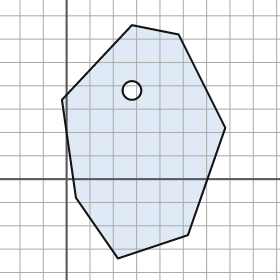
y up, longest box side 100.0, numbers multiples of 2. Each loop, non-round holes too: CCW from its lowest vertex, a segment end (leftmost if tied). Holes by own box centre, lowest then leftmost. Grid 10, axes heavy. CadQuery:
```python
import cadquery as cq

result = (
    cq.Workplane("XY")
    .moveTo(22.0, -34.0)
    .lineTo(52.0, -24.0)
    .lineTo(68.0, 22.0)
    .lineTo(48.0, 62.0)
    .lineTo(28.0, 66.0)
    .lineTo(-2.0, 34.0)
    .lineTo(4.0, -8.0)
    .close()
    .moveTo(28.0, 38.0)
    .circle(4.0)
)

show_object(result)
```